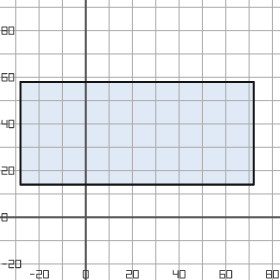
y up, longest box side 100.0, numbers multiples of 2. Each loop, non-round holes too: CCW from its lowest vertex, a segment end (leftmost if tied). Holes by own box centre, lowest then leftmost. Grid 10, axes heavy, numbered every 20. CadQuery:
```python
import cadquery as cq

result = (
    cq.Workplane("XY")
    .moveTo(-28.0, 14.0)
    .lineTo(72.0, 14.0)
    .lineTo(72.0, 58.0)
    .lineTo(-28.0, 58.0)
    .close()
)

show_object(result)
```